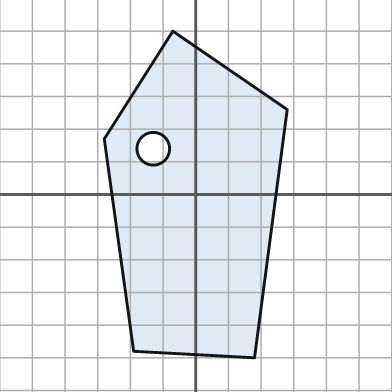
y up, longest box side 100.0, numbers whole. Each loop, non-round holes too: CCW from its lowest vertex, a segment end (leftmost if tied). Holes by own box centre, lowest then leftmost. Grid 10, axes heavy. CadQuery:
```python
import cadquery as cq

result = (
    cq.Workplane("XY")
    .moveTo(18.0, -50.0)
    .lineTo(28.0, 26.0)
    .lineTo(-7.0, 50.0)
    .lineTo(-28.0, 17.0)
    .lineTo(-19.0, -48.0)
    .close()
    .moveTo(-13.0, 14.0)
    .circle(5.0)
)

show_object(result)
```